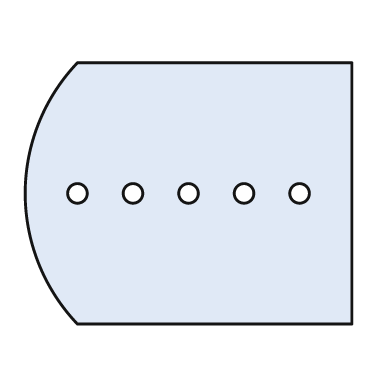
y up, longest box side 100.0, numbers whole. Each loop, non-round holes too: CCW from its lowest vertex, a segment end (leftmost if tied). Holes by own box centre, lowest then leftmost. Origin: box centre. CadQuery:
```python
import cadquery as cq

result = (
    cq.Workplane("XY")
    .moveTo(-34.0, -40.0)
    .lineTo(50.0, -40.0)
    .lineTo(50.0, 40.0)
    .lineTo(-34.0, 40.0)
    .threePointArc((-50.0, 0.0), (-34.0, -40.0))
    .close()
    .moveTo(-34.0, 0.0)
    .circle(3.0)
    .moveTo(-17.0, 0.0)
    .circle(3.0)
    .moveTo(0.0, 0.0)
    .circle(3.0)
    .moveTo(17.0, 0.0)
    .circle(3.0)
    .moveTo(34.0, 0.0)
    .circle(3.0)
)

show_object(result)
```